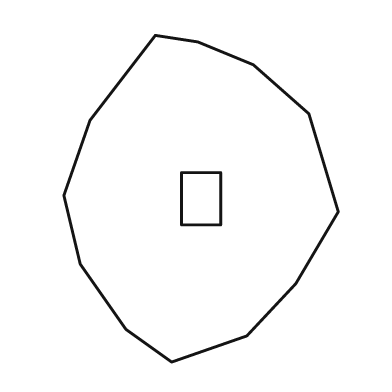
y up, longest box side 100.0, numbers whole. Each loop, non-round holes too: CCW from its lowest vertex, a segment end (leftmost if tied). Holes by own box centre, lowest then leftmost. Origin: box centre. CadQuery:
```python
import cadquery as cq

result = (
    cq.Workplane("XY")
    .moveTo(-9.0, -50.0)
    .lineTo(14.0, -42.0)
    .lineTo(29.0, -26.0)
    .lineTo(42.0, -4.0)
    .lineTo(33.0, 26.0)
    .lineTo(16.0, 41.0)
    .lineTo(-1.0, 48.0)
    .lineTo(-14.0, 50.0)
    .lineTo(-34.0, 24.0)
    .lineTo(-42.0, 1.0)
    .lineTo(-37.0, -20.0)
    .lineTo(-23.0, -40.0)
    .close()
    .moveTo(-6.0, -8.0)
    .lineTo(6.0, -8.0)
    .lineTo(6.0, 8.0)
    .lineTo(-6.0, 8.0)
    .close()
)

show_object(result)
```